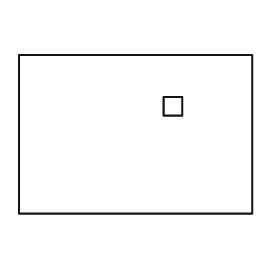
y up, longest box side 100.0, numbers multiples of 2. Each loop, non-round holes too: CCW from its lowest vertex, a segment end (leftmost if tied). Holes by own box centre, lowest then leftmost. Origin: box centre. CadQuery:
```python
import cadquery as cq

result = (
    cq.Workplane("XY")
    .moveTo(-50.0, -34.0)
    .lineTo(50.0, -34.0)
    .lineTo(50.0, 34.0)
    .lineTo(-50.0, 34.0)
    .close()
    .moveTo(12.0, 8.0)
    .lineTo(20.0, 8.0)
    .lineTo(20.0, 16.0)
    .lineTo(12.0, 16.0)
    .close()
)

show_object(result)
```